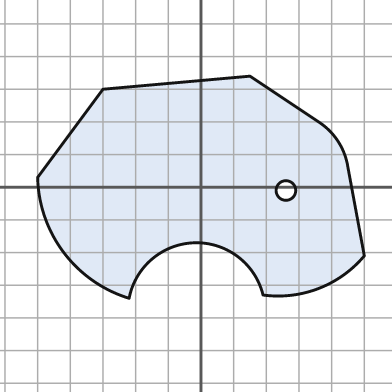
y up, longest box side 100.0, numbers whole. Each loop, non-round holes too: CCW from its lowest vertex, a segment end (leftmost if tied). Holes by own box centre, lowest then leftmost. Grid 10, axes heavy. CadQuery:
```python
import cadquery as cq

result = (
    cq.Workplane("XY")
    .moveTo(-22.0, -34.0)
    .threePointArc((-2.0, -17.0), (19.0, -33.0))
    .threePointArc((36.0, -31.0), (50.0, -21.0))
    .lineTo(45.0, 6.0)
    .threePointArc((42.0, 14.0), (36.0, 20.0))
    .lineTo(15.0, 34.0)
    .lineTo(-30.0, 30.0)
    .lineTo(-50.0, 3.0)
    .threePointArc((-42.0, -20.0), (-22.0, -34.0))
    .close()
    .moveTo(26.0, -1.0)
    .circle(3.0)
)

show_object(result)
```